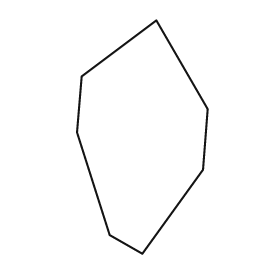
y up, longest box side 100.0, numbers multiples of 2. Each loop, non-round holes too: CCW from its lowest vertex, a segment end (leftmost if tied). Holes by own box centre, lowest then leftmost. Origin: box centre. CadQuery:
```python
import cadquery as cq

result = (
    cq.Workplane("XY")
    .moveTo(0.0, -50.0)
    .lineTo(26.0, -14.0)
    .lineTo(28.0, 12.0)
    .lineTo(6.0, 50.0)
    .lineTo(-26.0, 26.0)
    .lineTo(-28.0, 2.0)
    .lineTo(-14.0, -42.0)
    .close()
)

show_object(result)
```